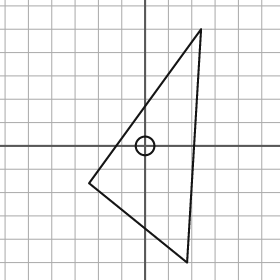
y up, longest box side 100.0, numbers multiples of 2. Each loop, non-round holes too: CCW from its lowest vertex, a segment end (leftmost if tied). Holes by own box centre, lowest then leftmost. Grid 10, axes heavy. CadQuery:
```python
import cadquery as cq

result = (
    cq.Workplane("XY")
    .moveTo(18.0, -50.0)
    .lineTo(24.0, 50.0)
    .lineTo(-24.0, -16.0)
    .close()
    .moveTo(0.0, 0.0)
    .circle(4.0)
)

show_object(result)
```